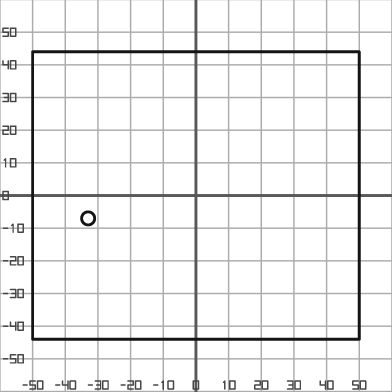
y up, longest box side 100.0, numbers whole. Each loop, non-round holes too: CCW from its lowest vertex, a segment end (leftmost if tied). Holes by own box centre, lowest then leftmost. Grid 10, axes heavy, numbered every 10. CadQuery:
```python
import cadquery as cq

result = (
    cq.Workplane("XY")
    .moveTo(-50.0, -44.0)
    .lineTo(50.0, -44.0)
    .lineTo(50.0, 44.0)
    .lineTo(-50.0, 44.0)
    .close()
    .moveTo(-33.0, -7.0)
    .circle(2.0)
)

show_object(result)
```